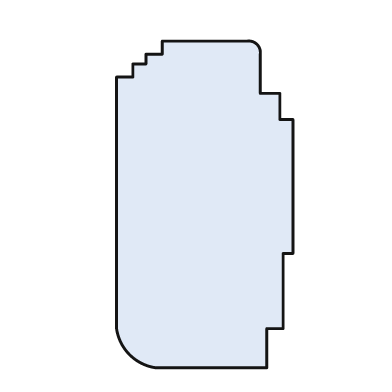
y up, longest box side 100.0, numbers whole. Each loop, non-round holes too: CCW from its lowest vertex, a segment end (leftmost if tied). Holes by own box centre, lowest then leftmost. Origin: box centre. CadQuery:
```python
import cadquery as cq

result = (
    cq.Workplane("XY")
    .moveTo(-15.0, -50.0)
    .lineTo(19.0, -50.0)
    .lineTo(19.0, -38.0)
    .lineTo(24.0, -38.0)
    .lineTo(24.0, -15.0)
    .lineTo(27.0, -15.0)
    .lineTo(27.0, 26.0)
    .lineTo(23.0, 26.0)
    .lineTo(23.0, 34.0)
    .lineTo(17.0, 34.0)
    .lineTo(17.0, 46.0)
    .threePointArc((16.0, 49.0), (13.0, 50.0))
    .lineTo(-13.0, 50.0)
    .lineTo(-13.0, 46.0)
    .lineTo(-18.0, 46.0)
    .lineTo(-18.0, 43.0)
    .lineTo(-22.0, 43.0)
    .lineTo(-22.0, 39.0)
    .lineTo(-27.0, 39.0)
    .lineTo(-27.0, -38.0)
    .threePointArc((-23.0, -46.0), (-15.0, -50.0))
    .close()
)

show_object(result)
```